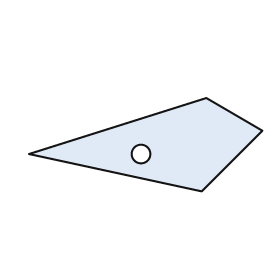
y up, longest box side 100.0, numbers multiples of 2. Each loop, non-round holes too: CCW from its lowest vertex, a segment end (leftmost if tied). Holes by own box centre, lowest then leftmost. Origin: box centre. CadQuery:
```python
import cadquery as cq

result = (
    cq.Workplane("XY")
    .moveTo(24.0, -20.0)
    .lineTo(50.0, 6.0)
    .lineTo(26.0, 20.0)
    .lineTo(-50.0, -4.0)
    .close()
    .moveTo(-2.0, -4.0)
    .circle(4.0)
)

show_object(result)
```